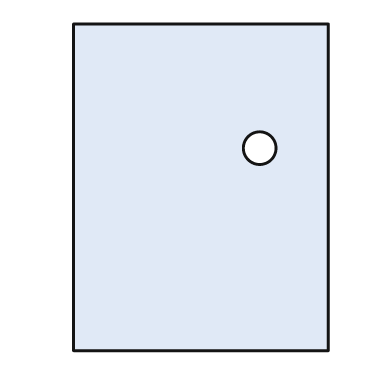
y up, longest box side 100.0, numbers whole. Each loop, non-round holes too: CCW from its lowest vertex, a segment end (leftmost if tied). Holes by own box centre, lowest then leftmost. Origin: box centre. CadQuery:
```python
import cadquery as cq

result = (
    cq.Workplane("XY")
    .moveTo(-39.0, -50.0)
    .lineTo(39.0, -50.0)
    .lineTo(39.0, 50.0)
    .lineTo(-39.0, 50.0)
    .close()
    .moveTo(18.0, 12.0)
    .circle(5.0)
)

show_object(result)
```